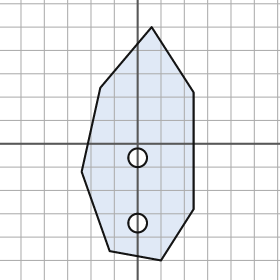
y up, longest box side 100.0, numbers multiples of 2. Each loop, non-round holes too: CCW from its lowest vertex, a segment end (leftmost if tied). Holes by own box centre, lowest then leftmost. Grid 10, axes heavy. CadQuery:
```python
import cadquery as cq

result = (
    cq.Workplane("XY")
    .moveTo(10.0, -50.0)
    .lineTo(24.0, -28.0)
    .lineTo(24.0, 22.0)
    .lineTo(6.0, 50.0)
    .lineTo(-16.0, 24.0)
    .lineTo(-24.0, -12.0)
    .lineTo(-12.0, -46.0)
    .close()
    .moveTo(0.0, -34.0)
    .circle(4.0)
    .moveTo(0.0, -6.0)
    .circle(4.0)
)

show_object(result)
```